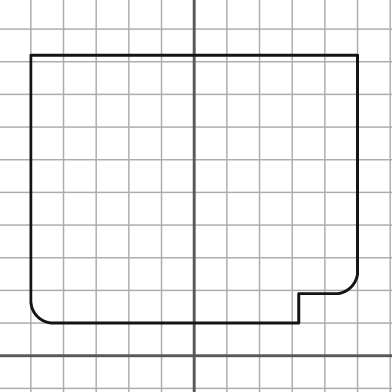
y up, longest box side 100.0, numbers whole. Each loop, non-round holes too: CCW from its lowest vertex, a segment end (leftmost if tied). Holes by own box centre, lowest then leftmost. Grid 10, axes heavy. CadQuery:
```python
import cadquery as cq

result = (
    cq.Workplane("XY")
    .moveTo(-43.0, 10.0)
    .lineTo(32.0, 10.0)
    .lineTo(32.0, 19.0)
    .lineTo(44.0, 19.0)
    .threePointArc((48.0, 21.0), (50.0, 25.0))
    .lineTo(50.0, 92.0)
    .lineTo(-50.0, 92.0)
    .lineTo(-50.0, 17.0)
    .threePointArc((-48.0, 12.0), (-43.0, 10.0))
    .close()
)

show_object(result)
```